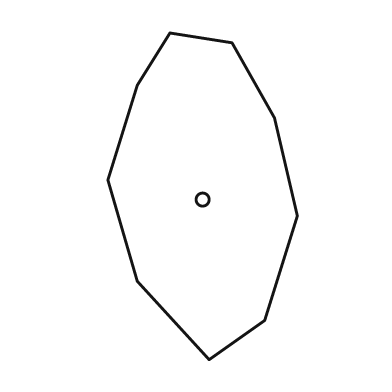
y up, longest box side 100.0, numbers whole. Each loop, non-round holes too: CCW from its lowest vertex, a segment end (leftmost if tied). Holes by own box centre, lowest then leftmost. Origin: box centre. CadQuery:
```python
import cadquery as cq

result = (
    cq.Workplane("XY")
    .moveTo(2.0, -50.0)
    .lineTo(19.0, -38.0)
    .lineTo(29.0, -6.0)
    .lineTo(22.0, 24.0)
    .lineTo(9.0, 47.0)
    .lineTo(-10.0, 50.0)
    .lineTo(-20.0, 34.0)
    .lineTo(-29.0, 5.0)
    .lineTo(-20.0, -26.0)
    .close()
    .moveTo(0.0, -1.0)
    .circle(2.0)
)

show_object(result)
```